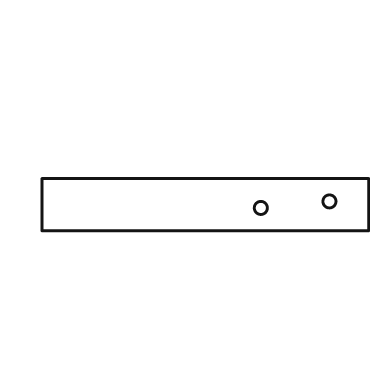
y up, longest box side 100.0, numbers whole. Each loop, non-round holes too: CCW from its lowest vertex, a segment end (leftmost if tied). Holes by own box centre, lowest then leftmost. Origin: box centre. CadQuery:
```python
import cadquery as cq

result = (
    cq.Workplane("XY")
    .moveTo(-50.0, -8.0)
    .lineTo(50.0, -8.0)
    .lineTo(50.0, 8.0)
    .lineTo(-50.0, 8.0)
    .close()
    .moveTo(17.0, -1.0)
    .circle(2.0)
    .moveTo(38.0, 1.0)
    .circle(2.0)
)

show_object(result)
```